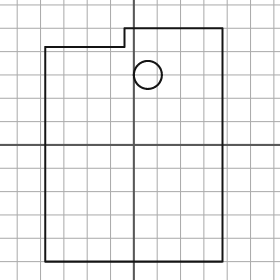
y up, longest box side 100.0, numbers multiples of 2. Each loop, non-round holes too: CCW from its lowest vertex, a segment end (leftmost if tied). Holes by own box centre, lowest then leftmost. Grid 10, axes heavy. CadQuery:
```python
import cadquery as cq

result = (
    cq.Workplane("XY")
    .moveTo(-38.0, -50.0)
    .lineTo(38.0, -50.0)
    .lineTo(38.0, 50.0)
    .lineTo(-4.0, 50.0)
    .lineTo(-4.0, 42.0)
    .lineTo(-38.0, 42.0)
    .close()
    .moveTo(6.0, 30.0)
    .circle(6.0)
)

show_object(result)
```